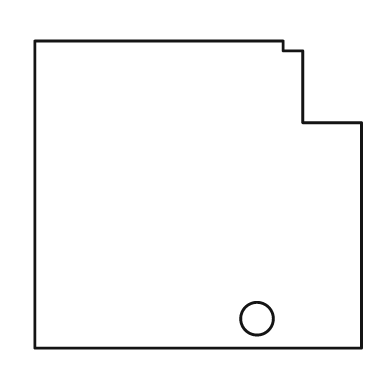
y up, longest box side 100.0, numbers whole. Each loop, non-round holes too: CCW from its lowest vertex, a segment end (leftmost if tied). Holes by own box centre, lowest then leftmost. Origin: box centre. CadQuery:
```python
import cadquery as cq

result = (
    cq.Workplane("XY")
    .moveTo(-50.0, -47.0)
    .lineTo(50.0, -47.0)
    .lineTo(50.0, 22.0)
    .lineTo(32.0, 22.0)
    .lineTo(32.0, 44.0)
    .lineTo(26.0, 44.0)
    .lineTo(26.0, 47.0)
    .lineTo(-50.0, 47.0)
    .close()
    .moveTo(18.0, -38.0)
    .circle(5.0)
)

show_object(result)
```